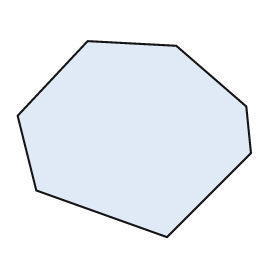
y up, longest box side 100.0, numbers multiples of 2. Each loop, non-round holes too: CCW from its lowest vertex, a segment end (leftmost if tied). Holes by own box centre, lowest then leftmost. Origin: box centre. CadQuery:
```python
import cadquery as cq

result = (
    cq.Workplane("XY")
    .moveTo(14.0, -42.0)
    .lineTo(50.0, -6.0)
    .lineTo(48.0, 14.0)
    .lineTo(18.0, 40.0)
    .lineTo(-20.0, 42.0)
    .lineTo(-50.0, 10.0)
    .lineTo(-42.0, -22.0)
    .close()
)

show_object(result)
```